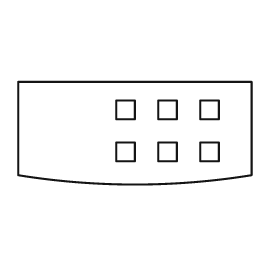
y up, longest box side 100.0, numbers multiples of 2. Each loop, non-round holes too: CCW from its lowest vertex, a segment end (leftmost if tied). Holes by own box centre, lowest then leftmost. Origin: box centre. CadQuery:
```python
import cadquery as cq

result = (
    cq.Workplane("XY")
    .moveTo(-50.0, -18.0)
    .threePointArc((0.0, -22.0), (50.0, -18.0))
    .lineTo(50.0, 22.0)
    .lineTo(-50.0, 22.0)
    .close()
    .moveTo(-8.0, -12.0)
    .lineTo(0.0, -12.0)
    .lineTo(0.0, -4.0)
    .lineTo(-8.0, -4.0)
    .close()
    .moveTo(10.0, -12.0)
    .lineTo(18.0, -12.0)
    .lineTo(18.0, -4.0)
    .lineTo(10.0, -4.0)
    .close()
    .moveTo(28.0, -12.0)
    .lineTo(36.0, -12.0)
    .lineTo(36.0, -4.0)
    .lineTo(28.0, -4.0)
    .close()
    .moveTo(-8.0, 6.0)
    .lineTo(0.0, 6.0)
    .lineTo(0.0, 14.0)
    .lineTo(-8.0, 14.0)
    .close()
    .moveTo(10.0, 6.0)
    .lineTo(18.0, 6.0)
    .lineTo(18.0, 14.0)
    .lineTo(10.0, 14.0)
    .close()
    .moveTo(28.0, 6.0)
    .lineTo(36.0, 6.0)
    .lineTo(36.0, 14.0)
    .lineTo(28.0, 14.0)
    .close()
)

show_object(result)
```